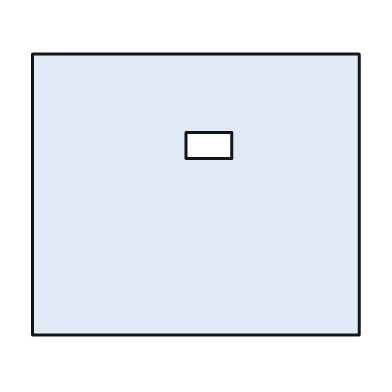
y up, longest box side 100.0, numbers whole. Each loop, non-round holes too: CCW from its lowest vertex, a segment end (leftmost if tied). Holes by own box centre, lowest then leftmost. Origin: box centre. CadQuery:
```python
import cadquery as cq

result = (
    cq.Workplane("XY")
    .moveTo(-50.0, -43.0)
    .lineTo(50.0, -43.0)
    .lineTo(50.0, 43.0)
    .lineTo(-50.0, 43.0)
    .close()
    .moveTo(-3.0, 11.0)
    .lineTo(11.0, 11.0)
    .lineTo(11.0, 19.0)
    .lineTo(-3.0, 19.0)
    .close()
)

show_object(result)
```